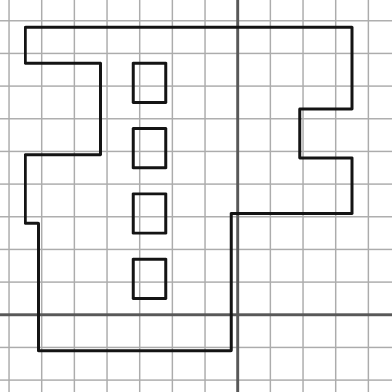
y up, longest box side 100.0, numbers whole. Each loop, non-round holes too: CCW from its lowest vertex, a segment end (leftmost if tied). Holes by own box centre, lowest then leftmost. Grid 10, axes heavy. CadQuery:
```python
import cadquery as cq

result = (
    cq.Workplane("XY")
    .moveTo(-61.0, -11.0)
    .lineTo(-2.0, -11.0)
    .lineTo(-2.0, 31.0)
    .lineTo(35.0, 31.0)
    .lineTo(35.0, 48.0)
    .lineTo(19.0, 48.0)
    .lineTo(19.0, 63.0)
    .lineTo(35.0, 63.0)
    .lineTo(35.0, 88.0)
    .lineTo(-65.0, 88.0)
    .lineTo(-65.0, 77.0)
    .lineTo(-42.0, 77.0)
    .lineTo(-42.0, 49.0)
    .lineTo(-65.0, 49.0)
    .lineTo(-65.0, 28.0)
    .lineTo(-61.0, 28.0)
    .close()
    .moveTo(-32.0, 5.0)
    .lineTo(-22.0, 5.0)
    .lineTo(-22.0, 17.0)
    .lineTo(-32.0, 17.0)
    .close()
    .moveTo(-32.0, 25.0)
    .lineTo(-22.0, 25.0)
    .lineTo(-22.0, 37.0)
    .lineTo(-32.0, 37.0)
    .close()
    .moveTo(-32.0, 45.0)
    .lineTo(-22.0, 45.0)
    .lineTo(-22.0, 57.0)
    .lineTo(-32.0, 57.0)
    .close()
    .moveTo(-32.0, 65.0)
    .lineTo(-22.0, 65.0)
    .lineTo(-22.0, 77.0)
    .lineTo(-32.0, 77.0)
    .close()
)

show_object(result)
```